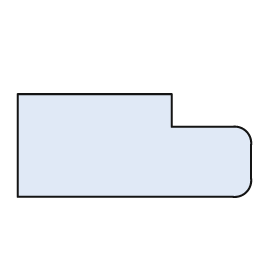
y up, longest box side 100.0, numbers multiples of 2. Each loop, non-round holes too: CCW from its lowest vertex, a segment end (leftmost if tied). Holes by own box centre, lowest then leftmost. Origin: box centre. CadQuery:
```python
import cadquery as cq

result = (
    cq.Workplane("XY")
    .moveTo(-50.0, -22.0)
    .lineTo(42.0, -22.0)
    .threePointArc((48.0, -20.0), (50.0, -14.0))
    .lineTo(50.0, 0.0)
    .threePointArc((48.0, 6.0), (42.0, 8.0))
    .lineTo(16.0, 8.0)
    .lineTo(16.0, 22.0)
    .lineTo(-50.0, 22.0)
    .close()
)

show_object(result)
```